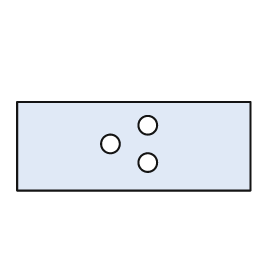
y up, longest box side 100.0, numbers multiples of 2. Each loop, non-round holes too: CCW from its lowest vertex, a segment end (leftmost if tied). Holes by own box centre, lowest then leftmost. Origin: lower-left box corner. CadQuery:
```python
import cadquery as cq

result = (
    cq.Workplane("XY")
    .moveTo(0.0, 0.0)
    .lineTo(100.0, 0.0)
    .lineTo(100.0, 38.0)
    .lineTo(0.0, 38.0)
    .close()
    .moveTo(56.0, 12.0)
    .circle(4.0)
    .moveTo(40.0, 20.0)
    .circle(4.0)
    .moveTo(56.0, 28.0)
    .circle(4.0)
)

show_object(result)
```